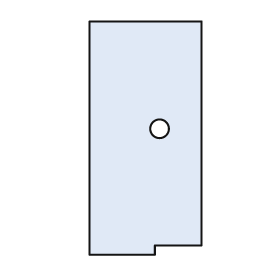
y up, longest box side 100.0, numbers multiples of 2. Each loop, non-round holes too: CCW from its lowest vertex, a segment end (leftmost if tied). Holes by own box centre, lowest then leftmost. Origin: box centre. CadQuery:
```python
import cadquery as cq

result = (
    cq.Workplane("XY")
    .moveTo(-24.0, -50.0)
    .lineTo(4.0, -50.0)
    .lineTo(4.0, -46.0)
    .lineTo(24.0, -46.0)
    .lineTo(24.0, 50.0)
    .lineTo(-24.0, 50.0)
    .close()
    .moveTo(6.0, 4.0)
    .circle(4.0)
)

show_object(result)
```